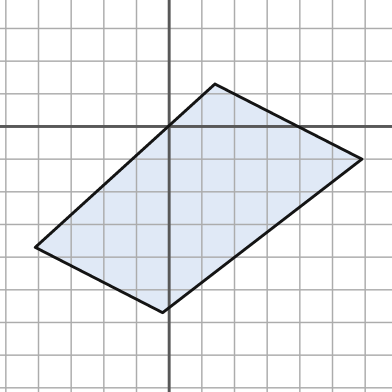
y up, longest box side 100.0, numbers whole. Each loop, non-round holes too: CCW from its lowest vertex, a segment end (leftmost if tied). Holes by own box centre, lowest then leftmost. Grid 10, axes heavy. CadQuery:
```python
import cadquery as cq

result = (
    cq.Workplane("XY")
    .moveTo(-2.0, -57.0)
    .lineTo(59.0, -10.0)
    .lineTo(14.0, 13.0)
    .lineTo(-41.0, -37.0)
    .close()
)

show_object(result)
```